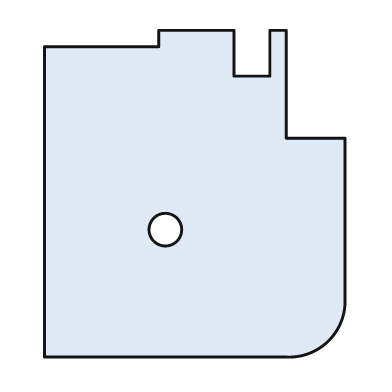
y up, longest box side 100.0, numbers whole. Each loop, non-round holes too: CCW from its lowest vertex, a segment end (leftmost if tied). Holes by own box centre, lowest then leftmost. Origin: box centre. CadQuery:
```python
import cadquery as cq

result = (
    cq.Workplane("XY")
    .moveTo(-46.0, -50.0)
    .lineTo(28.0, -50.0)
    .threePointArc((41.0, -45.0), (46.0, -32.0))
    .lineTo(46.0, 17.0)
    .lineTo(28.0, 17.0)
    .lineTo(28.0, 50.0)
    .lineTo(23.0, 50.0)
    .lineTo(23.0, 36.0)
    .lineTo(12.0, 36.0)
    .lineTo(12.0, 50.0)
    .lineTo(-11.0, 50.0)
    .lineTo(-11.0, 45.0)
    .lineTo(-46.0, 45.0)
    .close()
    .moveTo(-9.0, -11.0)
    .circle(5.0)
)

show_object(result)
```